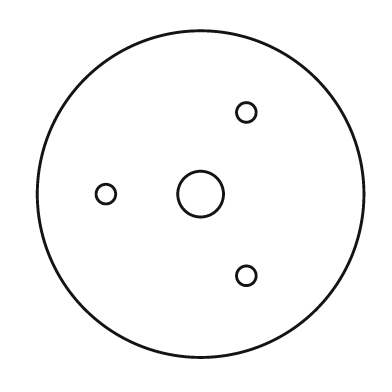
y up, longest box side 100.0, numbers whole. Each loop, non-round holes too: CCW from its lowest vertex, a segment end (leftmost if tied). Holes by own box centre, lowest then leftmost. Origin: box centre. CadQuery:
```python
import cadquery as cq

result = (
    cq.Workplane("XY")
    .moveTo(0.0, 0.0)
    .circle(50.0)
    .moveTo(14.0, -25.0)
    .circle(3.0)
    .moveTo(-29.0, 0.0)
    .circle(3.0)
    .moveTo(0.0, 0.0)
    .circle(7.0)
    .moveTo(14.0, 25.0)
    .circle(3.0)
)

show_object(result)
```